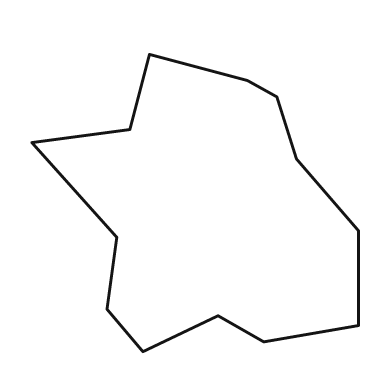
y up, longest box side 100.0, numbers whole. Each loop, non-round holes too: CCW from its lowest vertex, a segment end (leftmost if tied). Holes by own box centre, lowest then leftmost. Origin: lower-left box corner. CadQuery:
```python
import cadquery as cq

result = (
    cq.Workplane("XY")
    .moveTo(34.0, 0.0)
    .lineTo(57.0, 11.0)
    .lineTo(71.0, 3.0)
    .lineTo(100.0, 8.0)
    .lineTo(100.0, 37.0)
    .lineTo(81.0, 59.0)
    .lineTo(75.0, 78.0)
    .lineTo(66.0, 83.0)
    .lineTo(36.0, 91.0)
    .lineTo(30.0, 68.0)
    .lineTo(0.0, 64.0)
    .lineTo(26.0, 35.0)
    .lineTo(23.0, 13.0)
    .close()
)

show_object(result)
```